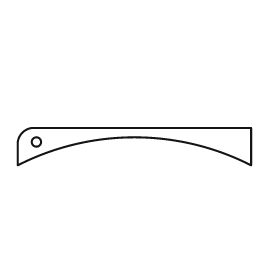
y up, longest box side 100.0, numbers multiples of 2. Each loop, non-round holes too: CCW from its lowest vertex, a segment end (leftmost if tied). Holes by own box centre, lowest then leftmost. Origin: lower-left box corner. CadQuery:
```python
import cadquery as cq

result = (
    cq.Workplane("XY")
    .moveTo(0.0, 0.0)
    .threePointArc((50.0, 12.0), (100.0, 0.0))
    .lineTo(100.0, 16.0)
    .lineTo(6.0, 16.0)
    .threePointArc((2.0, 14.0), (0.0, 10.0))
    .close()
    .moveTo(8.0, 10.0)
    .circle(2.0)
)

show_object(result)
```